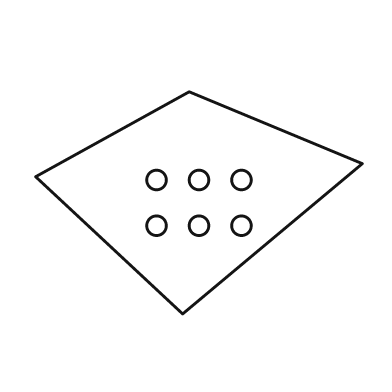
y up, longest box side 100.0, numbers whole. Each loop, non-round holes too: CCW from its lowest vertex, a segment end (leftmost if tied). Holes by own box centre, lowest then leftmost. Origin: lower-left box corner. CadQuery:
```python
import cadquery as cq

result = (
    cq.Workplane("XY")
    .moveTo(45.0, 0.0)
    .lineTo(100.0, 46.0)
    .lineTo(47.0, 68.0)
    .lineTo(0.0, 42.0)
    .close()
    .moveTo(37.0, 27.0)
    .circle(3.0)
    .moveTo(50.0, 27.0)
    .circle(3.0)
    .moveTo(63.0, 27.0)
    .circle(3.0)
    .moveTo(37.0, 41.0)
    .circle(3.0)
    .moveTo(50.0, 41.0)
    .circle(3.0)
    .moveTo(63.0, 41.0)
    .circle(3.0)
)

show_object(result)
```